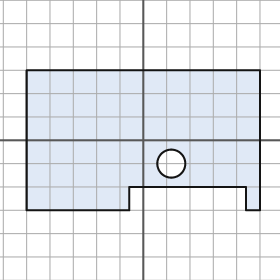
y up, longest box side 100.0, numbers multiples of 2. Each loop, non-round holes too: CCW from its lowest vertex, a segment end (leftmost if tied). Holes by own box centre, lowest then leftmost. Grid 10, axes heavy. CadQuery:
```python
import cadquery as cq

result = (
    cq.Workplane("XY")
    .moveTo(-50.0, -30.0)
    .lineTo(-6.0, -30.0)
    .lineTo(-6.0, -20.0)
    .lineTo(44.0, -20.0)
    .lineTo(44.0, -30.0)
    .lineTo(50.0, -30.0)
    .lineTo(50.0, 30.0)
    .lineTo(-50.0, 30.0)
    .close()
    .moveTo(12.0, -10.0)
    .circle(6.0)
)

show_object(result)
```